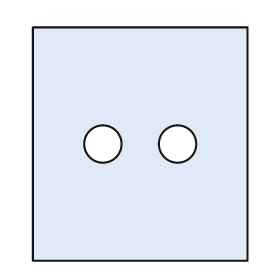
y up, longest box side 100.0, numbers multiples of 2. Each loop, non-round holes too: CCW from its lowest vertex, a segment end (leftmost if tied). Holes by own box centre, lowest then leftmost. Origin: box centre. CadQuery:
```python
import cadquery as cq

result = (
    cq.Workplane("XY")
    .moveTo(-46.0, -50.0)
    .lineTo(46.0, -50.0)
    .lineTo(46.0, 50.0)
    .lineTo(-46.0, 50.0)
    .close()
    .moveTo(-16.0, 0.0)
    .circle(8.0)
    .moveTo(16.0, 0.0)
    .circle(8.0)
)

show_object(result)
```